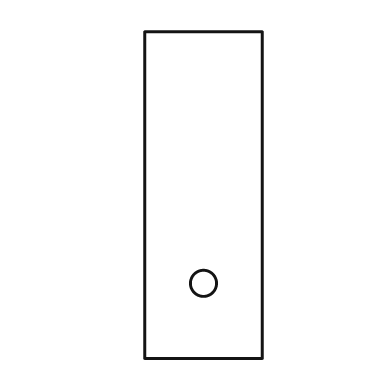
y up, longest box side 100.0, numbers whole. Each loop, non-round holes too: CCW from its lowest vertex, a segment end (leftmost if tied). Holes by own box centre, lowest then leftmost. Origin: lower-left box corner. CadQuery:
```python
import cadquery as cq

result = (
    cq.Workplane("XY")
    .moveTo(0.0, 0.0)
    .lineTo(36.0, 0.0)
    .lineTo(36.0, 100.0)
    .lineTo(0.0, 100.0)
    .close()
    .moveTo(18.0, 23.0)
    .circle(4.0)
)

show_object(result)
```